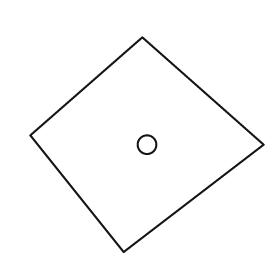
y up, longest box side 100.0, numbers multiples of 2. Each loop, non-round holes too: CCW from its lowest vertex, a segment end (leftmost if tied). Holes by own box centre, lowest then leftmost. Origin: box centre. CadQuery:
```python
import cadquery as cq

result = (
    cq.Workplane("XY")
    .moveTo(-10.0, -46.0)
    .lineTo(50.0, 0.0)
    .lineTo(-2.0, 46.0)
    .lineTo(-50.0, 4.0)
    .close()
    .moveTo(0.0, 0.0)
    .circle(4.0)
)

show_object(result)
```